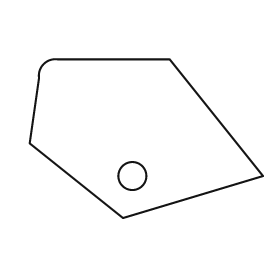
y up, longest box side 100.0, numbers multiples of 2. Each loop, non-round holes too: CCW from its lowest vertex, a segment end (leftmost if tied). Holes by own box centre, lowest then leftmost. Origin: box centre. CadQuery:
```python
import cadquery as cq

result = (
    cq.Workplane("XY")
    .moveTo(-10.0, -34.0)
    .lineTo(50.0, -16.0)
    .lineTo(10.0, 34.0)
    .lineTo(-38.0, 34.0)
    .threePointArc((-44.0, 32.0), (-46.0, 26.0))
    .lineTo(-50.0, -2.0)
    .close()
    .moveTo(-6.0, -16.0)
    .circle(6.0)
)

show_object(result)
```